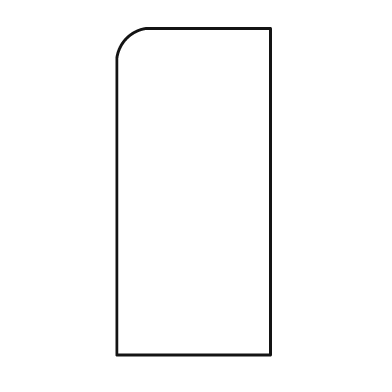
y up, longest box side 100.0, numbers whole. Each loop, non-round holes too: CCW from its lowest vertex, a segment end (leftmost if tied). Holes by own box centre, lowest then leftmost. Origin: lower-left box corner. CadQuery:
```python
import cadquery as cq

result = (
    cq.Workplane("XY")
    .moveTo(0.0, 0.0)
    .lineTo(47.0, 0.0)
    .lineTo(47.0, 100.0)
    .lineTo(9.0, 100.0)
    .threePointArc((3.0, 97.0), (0.0, 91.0))
    .close()
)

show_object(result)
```